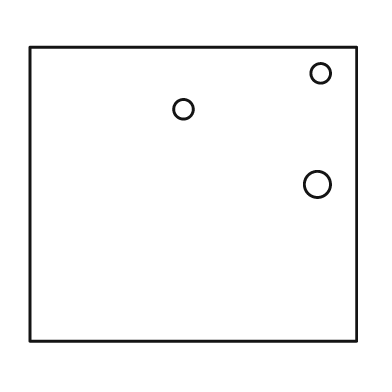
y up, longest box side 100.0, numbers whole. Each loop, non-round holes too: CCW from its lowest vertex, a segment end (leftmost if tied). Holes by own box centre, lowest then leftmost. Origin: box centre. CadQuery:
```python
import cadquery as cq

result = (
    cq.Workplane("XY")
    .moveTo(-50.0, -45.0)
    .lineTo(50.0, -45.0)
    .lineTo(50.0, 45.0)
    .lineTo(-50.0, 45.0)
    .close()
    .moveTo(38.0, 3.0)
    .circle(4.0)
    .moveTo(-3.0, 26.0)
    .circle(3.0)
    .moveTo(39.0, 37.0)
    .circle(3.0)
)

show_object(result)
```